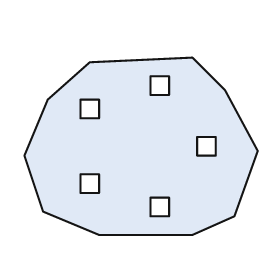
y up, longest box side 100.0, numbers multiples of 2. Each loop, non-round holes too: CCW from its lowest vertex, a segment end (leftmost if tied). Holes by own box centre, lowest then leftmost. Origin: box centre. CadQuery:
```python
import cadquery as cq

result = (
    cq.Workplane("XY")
    .moveTo(-18.0, -38.0)
    .lineTo(22.0, -38.0)
    .lineTo(40.0, -30.0)
    .lineTo(50.0, -2.0)
    .lineTo(36.0, 24.0)
    .lineTo(22.0, 38.0)
    .lineTo(-22.0, 36.0)
    .lineTo(-40.0, 20.0)
    .lineTo(-50.0, -4.0)
    .lineTo(-42.0, -28.0)
    .close()
    .moveTo(4.0, -30.0)
    .lineTo(12.0, -30.0)
    .lineTo(12.0, -22.0)
    .lineTo(4.0, -22.0)
    .close()
    .moveTo(-26.0, -20.0)
    .lineTo(-18.0, -20.0)
    .lineTo(-18.0, -12.0)
    .lineTo(-26.0, -12.0)
    .close()
    .moveTo(24.0, -4.0)
    .lineTo(32.0, -4.0)
    .lineTo(32.0, 4.0)
    .lineTo(24.0, 4.0)
    .close()
    .moveTo(-26.0, 12.0)
    .lineTo(-18.0, 12.0)
    .lineTo(-18.0, 20.0)
    .lineTo(-26.0, 20.0)
    .close()
    .moveTo(4.0, 22.0)
    .lineTo(12.0, 22.0)
    .lineTo(12.0, 30.0)
    .lineTo(4.0, 30.0)
    .close()
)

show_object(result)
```